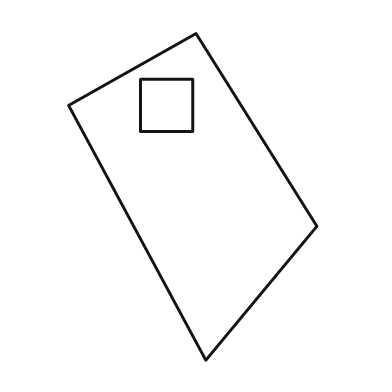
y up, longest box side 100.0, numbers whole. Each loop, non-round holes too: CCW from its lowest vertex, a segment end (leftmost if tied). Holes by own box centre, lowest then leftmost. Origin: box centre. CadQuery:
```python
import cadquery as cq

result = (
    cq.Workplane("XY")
    .moveTo(4.0, -50.0)
    .lineTo(38.0, -9.0)
    .lineTo(1.0, 50.0)
    .lineTo(-38.0, 28.0)
    .close()
    .moveTo(-16.0, 20.0)
    .lineTo(0.0, 20.0)
    .lineTo(0.0, 36.0)
    .lineTo(-16.0, 36.0)
    .close()
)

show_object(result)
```